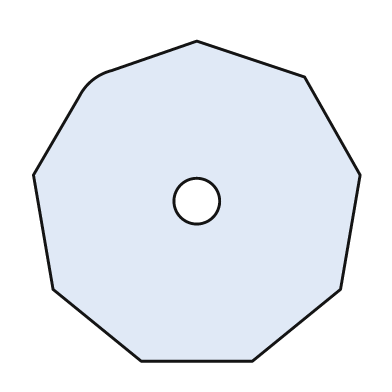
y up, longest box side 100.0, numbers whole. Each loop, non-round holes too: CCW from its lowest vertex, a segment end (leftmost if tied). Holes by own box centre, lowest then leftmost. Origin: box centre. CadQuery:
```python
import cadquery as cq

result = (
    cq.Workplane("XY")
    .moveTo(-17.0, -49.0)
    .lineTo(17.0, -49.0)
    .lineTo(44.0, -27.0)
    .lineTo(50.0, 8.0)
    .lineTo(33.0, 38.0)
    .lineTo(0.0, 49.0)
    .lineTo(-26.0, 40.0)
    .threePointArc((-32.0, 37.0), (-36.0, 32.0))
    .lineTo(-50.0, 8.0)
    .lineTo(-44.0, -27.0)
    .close()
    .moveTo(0.0, 0.0)
    .circle(7.0)
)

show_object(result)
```